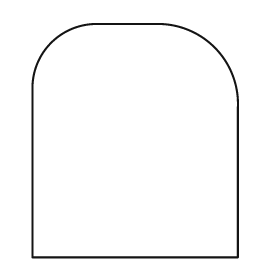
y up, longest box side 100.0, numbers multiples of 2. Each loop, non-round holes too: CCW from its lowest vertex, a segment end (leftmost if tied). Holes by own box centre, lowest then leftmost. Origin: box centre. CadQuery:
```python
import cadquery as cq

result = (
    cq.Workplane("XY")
    .moveTo(-44.0, -50.0)
    .lineTo(44.0, -50.0)
    .lineTo(44.0, 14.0)
    .threePointArc((34.0, 40.0), (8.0, 50.0))
    .lineTo(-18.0, 50.0)
    .threePointArc((-36.0, 42.0), (-44.0, 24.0))
    .close()
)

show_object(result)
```